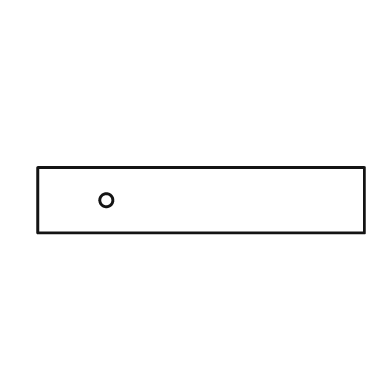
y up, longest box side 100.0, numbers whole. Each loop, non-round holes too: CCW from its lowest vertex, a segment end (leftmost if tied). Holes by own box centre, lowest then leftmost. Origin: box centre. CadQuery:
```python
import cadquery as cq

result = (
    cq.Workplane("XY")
    .moveTo(-50.0, -10.0)
    .lineTo(50.0, -10.0)
    .lineTo(50.0, 10.0)
    .lineTo(-50.0, 10.0)
    .close()
    .moveTo(-29.0, 0.0)
    .circle(2.0)
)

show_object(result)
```